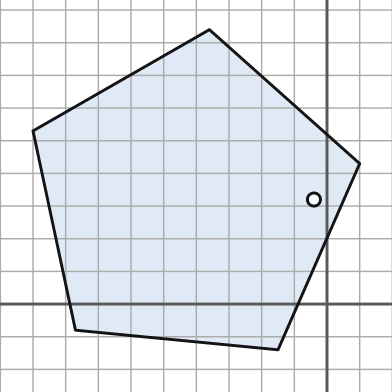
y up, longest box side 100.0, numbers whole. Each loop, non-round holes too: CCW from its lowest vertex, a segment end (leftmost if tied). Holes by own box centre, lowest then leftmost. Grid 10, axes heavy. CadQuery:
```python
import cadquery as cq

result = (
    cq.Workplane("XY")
    .moveTo(-15.0, -14.0)
    .lineTo(10.0, 43.0)
    .lineTo(-36.0, 84.0)
    .lineTo(-90.0, 53.0)
    .lineTo(-77.0, -8.0)
    .close()
    .moveTo(-4.0, 32.0)
    .circle(2.0)
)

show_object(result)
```